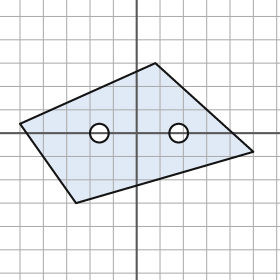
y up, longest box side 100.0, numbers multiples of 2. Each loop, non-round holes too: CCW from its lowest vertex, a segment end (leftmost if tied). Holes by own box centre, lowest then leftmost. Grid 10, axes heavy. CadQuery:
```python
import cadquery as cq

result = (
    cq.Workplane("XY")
    .moveTo(-26.0, -30.0)
    .lineTo(50.0, -8.0)
    .lineTo(8.0, 30.0)
    .lineTo(-50.0, 4.0)
    .close()
    .moveTo(-16.0, 0.0)
    .circle(4.0)
    .moveTo(18.0, 0.0)
    .circle(4.0)
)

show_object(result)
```